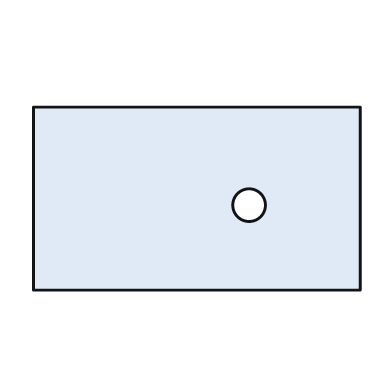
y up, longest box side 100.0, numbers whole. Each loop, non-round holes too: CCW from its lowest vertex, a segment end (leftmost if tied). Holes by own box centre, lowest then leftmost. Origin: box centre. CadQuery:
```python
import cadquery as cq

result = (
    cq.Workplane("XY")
    .moveTo(-50.0, -28.0)
    .lineTo(50.0, -28.0)
    .lineTo(50.0, 28.0)
    .lineTo(-50.0, 28.0)
    .close()
    .moveTo(16.0, -2.0)
    .circle(5.0)
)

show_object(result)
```